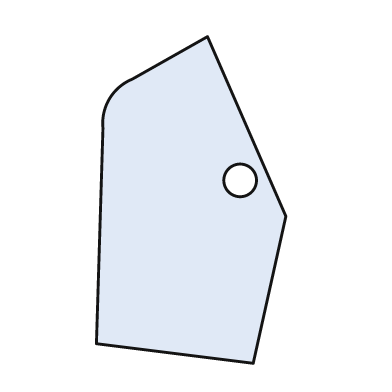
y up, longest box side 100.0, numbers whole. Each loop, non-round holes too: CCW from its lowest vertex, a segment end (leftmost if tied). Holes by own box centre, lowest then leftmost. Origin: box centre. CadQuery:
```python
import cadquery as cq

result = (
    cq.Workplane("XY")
    .moveTo(19.0, -50.0)
    .lineTo(29.0, -5.0)
    .lineTo(5.0, 50.0)
    .lineTo(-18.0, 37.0)
    .threePointArc((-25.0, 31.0), (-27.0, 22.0))
    .lineTo(-29.0, -44.0)
    .close()
    .moveTo(15.0, 6.0)
    .circle(5.0)
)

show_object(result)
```